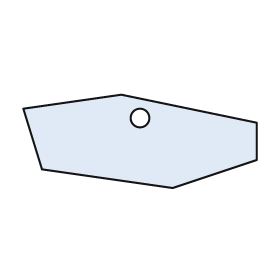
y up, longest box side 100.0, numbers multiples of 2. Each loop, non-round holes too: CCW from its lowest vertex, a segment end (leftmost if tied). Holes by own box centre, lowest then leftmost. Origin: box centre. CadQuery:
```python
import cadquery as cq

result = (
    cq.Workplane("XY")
    .moveTo(14.0, -20.0)
    .lineTo(50.0, -8.0)
    .lineTo(50.0, 8.0)
    .lineTo(-8.0, 20.0)
    .lineTo(-50.0, 14.0)
    .lineTo(-42.0, -12.0)
    .close()
    .moveTo(0.0, 10.0)
    .circle(4.0)
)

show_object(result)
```